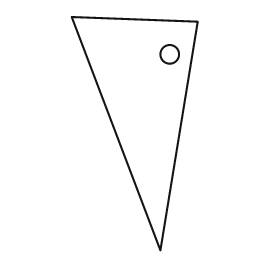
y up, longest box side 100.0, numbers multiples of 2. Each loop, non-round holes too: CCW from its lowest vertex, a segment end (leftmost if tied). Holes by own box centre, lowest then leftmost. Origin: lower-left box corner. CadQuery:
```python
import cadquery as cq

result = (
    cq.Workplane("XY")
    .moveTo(38.0, 0.0)
    .lineTo(54.0, 98.0)
    .lineTo(0.0, 100.0)
    .close()
    .moveTo(42.0, 84.0)
    .circle(4.0)
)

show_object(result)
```